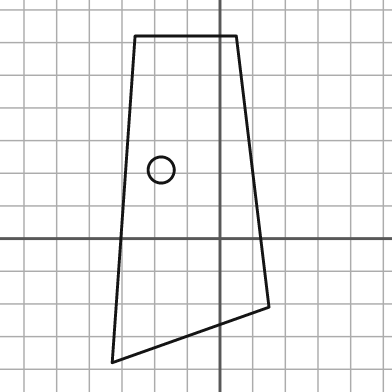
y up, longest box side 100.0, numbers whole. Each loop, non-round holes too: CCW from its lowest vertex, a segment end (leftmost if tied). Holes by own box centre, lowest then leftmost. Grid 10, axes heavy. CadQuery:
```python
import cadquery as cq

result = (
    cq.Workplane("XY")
    .moveTo(-33.0, -38.0)
    .lineTo(15.0, -21.0)
    .lineTo(5.0, 62.0)
    .lineTo(-26.0, 62.0)
    .close()
    .moveTo(-18.0, 21.0)
    .circle(4.0)
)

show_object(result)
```